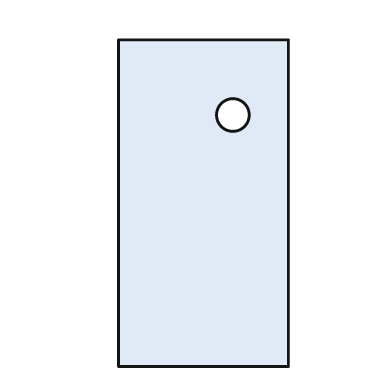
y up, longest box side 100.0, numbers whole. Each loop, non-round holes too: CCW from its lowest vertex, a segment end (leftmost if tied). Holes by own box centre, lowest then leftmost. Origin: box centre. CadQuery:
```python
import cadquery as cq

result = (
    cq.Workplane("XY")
    .moveTo(-26.0, -50.0)
    .lineTo(26.0, -50.0)
    .lineTo(26.0, 50.0)
    .lineTo(-26.0, 50.0)
    .close()
    .moveTo(9.0, 27.0)
    .circle(5.0)
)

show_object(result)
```